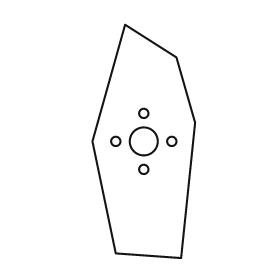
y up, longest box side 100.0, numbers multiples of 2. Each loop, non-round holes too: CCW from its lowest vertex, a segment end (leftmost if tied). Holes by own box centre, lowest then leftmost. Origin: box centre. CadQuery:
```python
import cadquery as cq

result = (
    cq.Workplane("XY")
    .moveTo(16.0, -50.0)
    .lineTo(22.0, 8.0)
    .lineTo(14.0, 36.0)
    .lineTo(-8.0, 50.0)
    .lineTo(-22.0, 0.0)
    .lineTo(-12.0, -48.0)
    .close()
    .moveTo(0.0, -12.0)
    .circle(2.0)
    .moveTo(-12.0, 0.0)
    .circle(2.0)
    .moveTo(0.0, 0.0)
    .circle(6.0)
    .moveTo(12.0, 0.0)
    .circle(2.0)
    .moveTo(0.0, 12.0)
    .circle(2.0)
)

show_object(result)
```